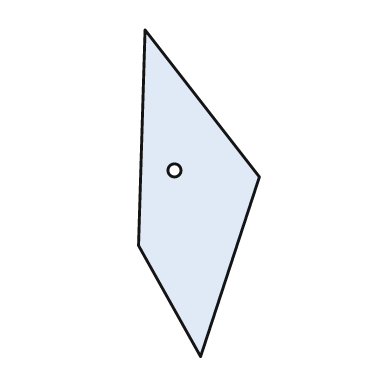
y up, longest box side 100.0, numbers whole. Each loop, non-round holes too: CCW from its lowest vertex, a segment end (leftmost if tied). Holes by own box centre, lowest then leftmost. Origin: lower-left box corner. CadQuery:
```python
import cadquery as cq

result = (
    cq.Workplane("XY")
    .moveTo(19.0, 0.0)
    .lineTo(37.0, 55.0)
    .lineTo(2.0, 100.0)
    .lineTo(0.0, 34.0)
    .close()
    .moveTo(11.0, 57.0)
    .circle(2.0)
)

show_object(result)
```